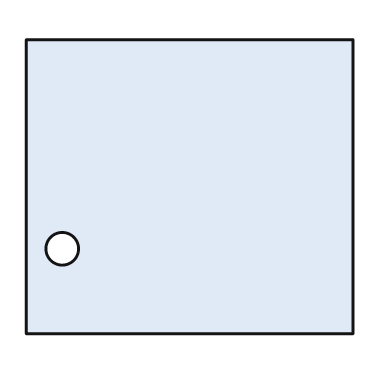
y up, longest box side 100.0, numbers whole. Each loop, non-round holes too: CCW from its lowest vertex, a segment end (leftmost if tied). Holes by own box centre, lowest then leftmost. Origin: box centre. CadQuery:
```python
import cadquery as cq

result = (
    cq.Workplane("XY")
    .moveTo(-50.0, -45.0)
    .lineTo(50.0, -45.0)
    .lineTo(50.0, 45.0)
    .lineTo(-50.0, 45.0)
    .close()
    .moveTo(-39.0, -19.0)
    .circle(5.0)
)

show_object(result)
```